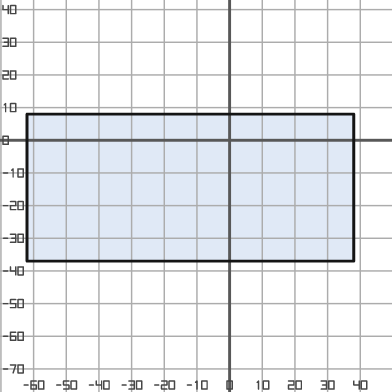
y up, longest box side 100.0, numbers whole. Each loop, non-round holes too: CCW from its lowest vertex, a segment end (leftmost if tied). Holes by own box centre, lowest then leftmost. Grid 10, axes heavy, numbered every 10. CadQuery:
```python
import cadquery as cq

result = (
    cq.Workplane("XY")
    .moveTo(-62.0, -37.0)
    .lineTo(38.0, -37.0)
    .lineTo(38.0, 8.0)
    .lineTo(-62.0, 8.0)
    .close()
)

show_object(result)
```